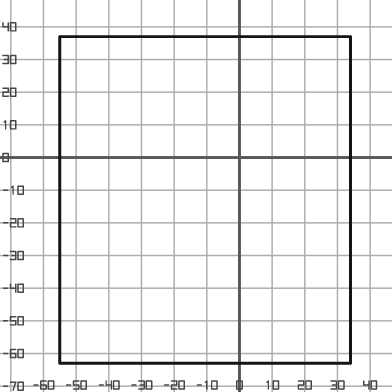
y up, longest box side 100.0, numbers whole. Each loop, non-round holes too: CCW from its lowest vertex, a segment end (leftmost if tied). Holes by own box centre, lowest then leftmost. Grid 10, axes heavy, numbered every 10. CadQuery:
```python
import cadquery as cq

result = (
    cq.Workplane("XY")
    .moveTo(-55.0, -63.0)
    .lineTo(34.0, -63.0)
    .lineTo(34.0, 37.0)
    .lineTo(-55.0, 37.0)
    .close()
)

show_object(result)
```